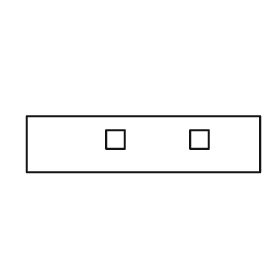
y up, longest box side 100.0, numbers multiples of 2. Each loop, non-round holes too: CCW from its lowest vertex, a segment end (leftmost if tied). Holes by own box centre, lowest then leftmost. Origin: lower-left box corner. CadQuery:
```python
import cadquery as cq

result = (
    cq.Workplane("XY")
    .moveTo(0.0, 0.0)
    .lineTo(100.0, 0.0)
    .lineTo(100.0, 24.0)
    .lineTo(0.0, 24.0)
    .close()
    .moveTo(34.0, 10.0)
    .lineTo(42.0, 10.0)
    .lineTo(42.0, 18.0)
    .lineTo(34.0, 18.0)
    .close()
    .moveTo(70.0, 10.0)
    .lineTo(78.0, 10.0)
    .lineTo(78.0, 18.0)
    .lineTo(70.0, 18.0)
    .close()
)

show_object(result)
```